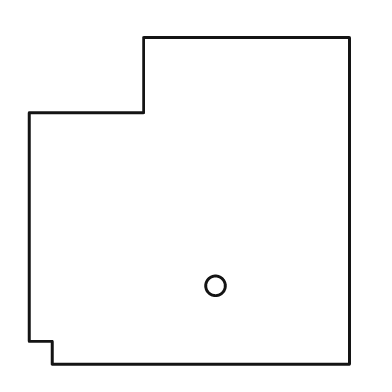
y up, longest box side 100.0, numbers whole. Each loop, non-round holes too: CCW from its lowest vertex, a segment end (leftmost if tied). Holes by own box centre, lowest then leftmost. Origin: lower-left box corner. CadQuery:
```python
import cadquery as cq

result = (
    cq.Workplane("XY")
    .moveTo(7.0, 0.0)
    .lineTo(98.0, 0.0)
    .lineTo(98.0, 100.0)
    .lineTo(35.0, 100.0)
    .lineTo(35.0, 77.0)
    .lineTo(0.0, 77.0)
    .lineTo(0.0, 7.0)
    .lineTo(7.0, 7.0)
    .close()
    .moveTo(57.0, 24.0)
    .circle(3.0)
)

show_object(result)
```